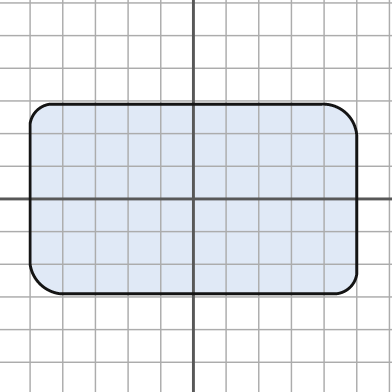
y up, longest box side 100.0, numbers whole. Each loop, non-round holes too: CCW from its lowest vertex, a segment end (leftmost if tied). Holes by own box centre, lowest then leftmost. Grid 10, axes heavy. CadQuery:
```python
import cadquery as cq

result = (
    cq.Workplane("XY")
    .moveTo(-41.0, -29.0)
    .lineTo(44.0, -29.0)
    .threePointArc((48.0, -27.0), (50.0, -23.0))
    .lineTo(50.0, 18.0)
    .threePointArc((47.0, 26.0), (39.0, 29.0))
    .lineTo(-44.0, 29.0)
    .threePointArc((-48.0, 27.0), (-50.0, 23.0))
    .lineTo(-50.0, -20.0)
    .threePointArc((-47.0, -26.0), (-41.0, -29.0))
    .close()
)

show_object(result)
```